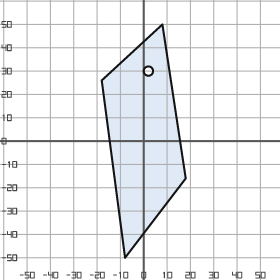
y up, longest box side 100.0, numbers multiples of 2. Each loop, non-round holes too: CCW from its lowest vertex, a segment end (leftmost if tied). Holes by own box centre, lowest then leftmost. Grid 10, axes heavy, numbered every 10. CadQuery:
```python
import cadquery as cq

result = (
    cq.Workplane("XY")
    .moveTo(-8.0, -50.0)
    .lineTo(18.0, -16.0)
    .lineTo(8.0, 50.0)
    .lineTo(-18.0, 26.0)
    .close()
    .moveTo(2.0, 30.0)
    .circle(2.0)
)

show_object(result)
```